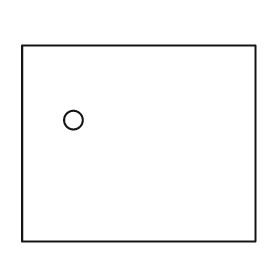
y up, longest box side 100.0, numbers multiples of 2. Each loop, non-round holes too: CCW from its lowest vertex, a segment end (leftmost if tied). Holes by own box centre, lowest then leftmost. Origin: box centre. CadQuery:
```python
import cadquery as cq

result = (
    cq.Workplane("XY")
    .moveTo(-50.0, -42.0)
    .lineTo(50.0, -42.0)
    .lineTo(50.0, 42.0)
    .lineTo(-50.0, 42.0)
    .close()
    .moveTo(-28.0, 10.0)
    .circle(4.0)
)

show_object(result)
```